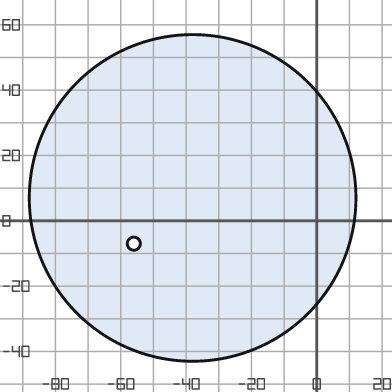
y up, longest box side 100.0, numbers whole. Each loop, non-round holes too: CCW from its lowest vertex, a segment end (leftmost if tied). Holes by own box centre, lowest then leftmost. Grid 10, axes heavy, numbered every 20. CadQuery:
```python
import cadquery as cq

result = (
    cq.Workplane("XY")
    .moveTo(-38.0, 7.0)
    .circle(50.0)
    .moveTo(-56.0, -7.0)
    .circle(2.0)
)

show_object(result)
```